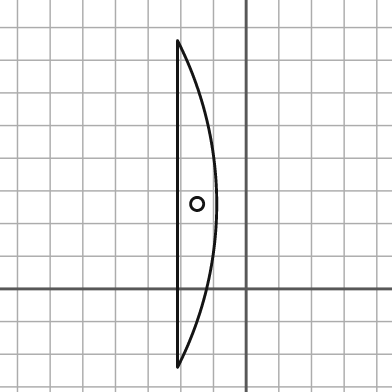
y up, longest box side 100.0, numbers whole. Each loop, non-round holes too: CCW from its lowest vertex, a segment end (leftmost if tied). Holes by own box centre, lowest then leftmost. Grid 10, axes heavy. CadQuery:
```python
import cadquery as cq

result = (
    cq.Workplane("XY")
    .moveTo(-21.0, -24.0)
    .threePointArc((-9.0, 26.0), (-21.0, 76.0))
    .close()
    .moveTo(-15.0, 26.0)
    .circle(2.0)
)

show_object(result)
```